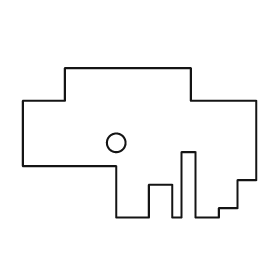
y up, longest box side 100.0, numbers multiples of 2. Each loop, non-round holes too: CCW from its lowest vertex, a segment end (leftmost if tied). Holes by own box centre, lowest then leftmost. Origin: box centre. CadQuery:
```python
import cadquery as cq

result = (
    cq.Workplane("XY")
    .moveTo(-10.0, -32.0)
    .lineTo(4.0, -32.0)
    .lineTo(4.0, -18.0)
    .lineTo(14.0, -18.0)
    .lineTo(14.0, -32.0)
    .lineTo(18.0, -32.0)
    .lineTo(18.0, -4.0)
    .lineTo(24.0, -4.0)
    .lineTo(24.0, -32.0)
    .lineTo(34.0, -32.0)
    .lineTo(34.0, -28.0)
    .lineTo(42.0, -28.0)
    .lineTo(42.0, -16.0)
    .lineTo(50.0, -16.0)
    .lineTo(50.0, 18.0)
    .lineTo(22.0, 18.0)
    .lineTo(22.0, 32.0)
    .lineTo(-32.0, 32.0)
    .lineTo(-32.0, 18.0)
    .lineTo(-50.0, 18.0)
    .lineTo(-50.0, -10.0)
    .lineTo(-10.0, -10.0)
    .close()
    .moveTo(-10.0, 0.0)
    .circle(4.0)
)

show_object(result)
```